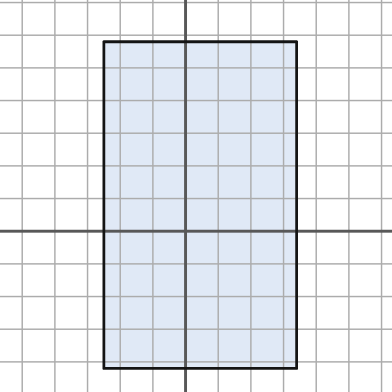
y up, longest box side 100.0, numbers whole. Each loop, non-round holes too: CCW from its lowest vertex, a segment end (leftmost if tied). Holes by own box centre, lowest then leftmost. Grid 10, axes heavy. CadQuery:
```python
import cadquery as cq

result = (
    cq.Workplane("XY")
    .moveTo(-25.0, -42.0)
    .lineTo(34.0, -42.0)
    .lineTo(34.0, 58.0)
    .lineTo(-25.0, 58.0)
    .close()
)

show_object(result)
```